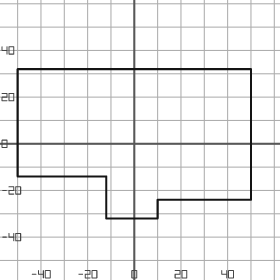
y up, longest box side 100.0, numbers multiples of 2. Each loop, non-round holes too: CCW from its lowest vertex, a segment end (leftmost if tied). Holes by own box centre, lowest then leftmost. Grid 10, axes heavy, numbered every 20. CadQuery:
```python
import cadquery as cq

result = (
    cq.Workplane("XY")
    .moveTo(-12.0, -32.0)
    .lineTo(10.0, -32.0)
    .lineTo(10.0, -24.0)
    .lineTo(50.0, -24.0)
    .lineTo(50.0, 32.0)
    .lineTo(-50.0, 32.0)
    .lineTo(-50.0, -14.0)
    .lineTo(-12.0, -14.0)
    .close()
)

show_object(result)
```